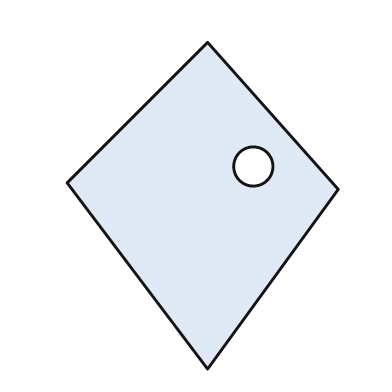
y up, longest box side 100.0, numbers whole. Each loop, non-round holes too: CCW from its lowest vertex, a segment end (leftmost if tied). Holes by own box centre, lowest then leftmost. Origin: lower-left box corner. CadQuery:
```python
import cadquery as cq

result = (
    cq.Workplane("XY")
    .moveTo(43.0, 0.0)
    .lineTo(83.0, 55.0)
    .lineTo(43.0, 100.0)
    .lineTo(0.0, 57.0)
    .close()
    .moveTo(57.0, 62.0)
    .circle(6.0)
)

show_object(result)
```